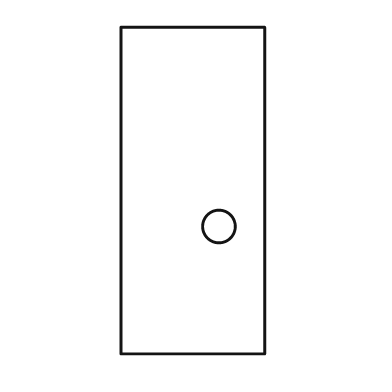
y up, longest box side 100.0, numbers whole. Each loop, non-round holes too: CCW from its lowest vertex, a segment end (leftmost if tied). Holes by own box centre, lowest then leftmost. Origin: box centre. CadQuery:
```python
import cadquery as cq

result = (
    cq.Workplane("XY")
    .moveTo(-22.0, -50.0)
    .lineTo(22.0, -50.0)
    .lineTo(22.0, 50.0)
    .lineTo(-22.0, 50.0)
    .close()
    .moveTo(8.0, -11.0)
    .circle(5.0)
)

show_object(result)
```